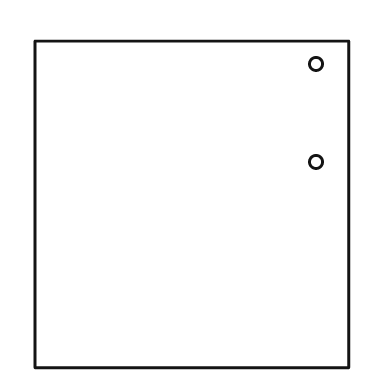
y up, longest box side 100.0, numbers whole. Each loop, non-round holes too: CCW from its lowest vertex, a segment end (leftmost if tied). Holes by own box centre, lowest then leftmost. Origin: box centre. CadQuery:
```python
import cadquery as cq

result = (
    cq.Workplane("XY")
    .moveTo(-48.0, -50.0)
    .lineTo(48.0, -50.0)
    .lineTo(48.0, 50.0)
    .lineTo(-48.0, 50.0)
    .close()
    .moveTo(38.0, 13.0)
    .circle(2.0)
    .moveTo(38.0, 43.0)
    .circle(2.0)
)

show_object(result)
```